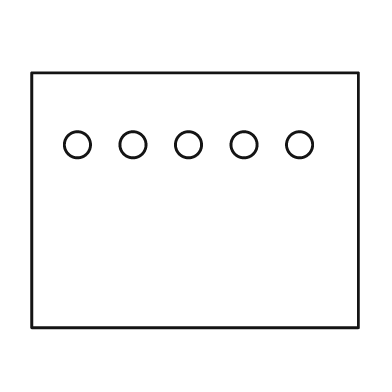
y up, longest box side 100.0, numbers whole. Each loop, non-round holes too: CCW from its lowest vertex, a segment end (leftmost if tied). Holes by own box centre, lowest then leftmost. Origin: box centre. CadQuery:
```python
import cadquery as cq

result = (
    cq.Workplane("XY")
    .moveTo(-50.0, -39.0)
    .lineTo(50.0, -39.0)
    .lineTo(50.0, 39.0)
    .lineTo(-50.0, 39.0)
    .close()
    .moveTo(-36.0, 17.0)
    .circle(4.0)
    .moveTo(-19.0, 17.0)
    .circle(4.0)
    .moveTo(-2.0, 17.0)
    .circle(4.0)
    .moveTo(15.0, 17.0)
    .circle(4.0)
    .moveTo(32.0, 17.0)
    .circle(4.0)
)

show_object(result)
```